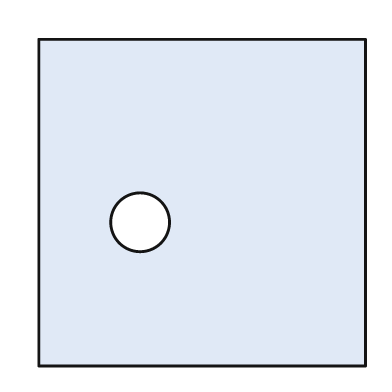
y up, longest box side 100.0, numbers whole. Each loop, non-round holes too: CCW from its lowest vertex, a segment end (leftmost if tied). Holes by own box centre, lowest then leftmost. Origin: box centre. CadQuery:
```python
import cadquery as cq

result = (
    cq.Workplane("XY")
    .moveTo(-50.0, -50.0)
    .lineTo(50.0, -50.0)
    .lineTo(50.0, 50.0)
    .lineTo(-50.0, 50.0)
    .close()
    .moveTo(-19.0, -6.0)
    .circle(9.0)
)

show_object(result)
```